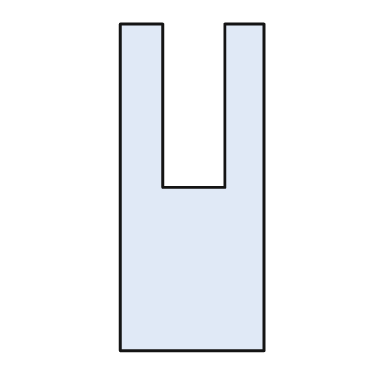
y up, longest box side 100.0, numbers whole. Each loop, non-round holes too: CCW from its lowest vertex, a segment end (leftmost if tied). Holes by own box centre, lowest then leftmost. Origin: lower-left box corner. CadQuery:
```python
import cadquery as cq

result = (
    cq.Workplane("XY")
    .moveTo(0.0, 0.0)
    .lineTo(44.0, 0.0)
    .lineTo(44.0, 100.0)
    .lineTo(32.0, 100.0)
    .lineTo(32.0, 50.0)
    .lineTo(13.0, 50.0)
    .lineTo(13.0, 100.0)
    .lineTo(0.0, 100.0)
    .close()
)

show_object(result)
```